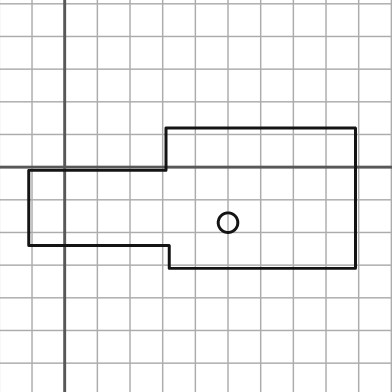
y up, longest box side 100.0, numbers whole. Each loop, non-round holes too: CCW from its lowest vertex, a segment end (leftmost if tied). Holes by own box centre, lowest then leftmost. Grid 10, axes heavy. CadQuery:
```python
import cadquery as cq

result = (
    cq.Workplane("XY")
    .moveTo(32.0, -31.0)
    .lineTo(89.0, -31.0)
    .lineTo(89.0, 12.0)
    .lineTo(31.0, 12.0)
    .lineTo(31.0, -1.0)
    .lineTo(-11.0, -1.0)
    .lineTo(-11.0, -24.0)
    .lineTo(32.0, -24.0)
    .close()
    .moveTo(50.0, -17.0)
    .circle(3.0)
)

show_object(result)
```